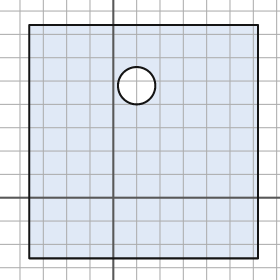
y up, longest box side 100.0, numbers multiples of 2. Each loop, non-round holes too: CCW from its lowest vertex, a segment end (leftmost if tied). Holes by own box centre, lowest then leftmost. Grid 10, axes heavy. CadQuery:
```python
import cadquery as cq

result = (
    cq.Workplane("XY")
    .moveTo(-36.0, -26.0)
    .lineTo(62.0, -26.0)
    .lineTo(62.0, 74.0)
    .lineTo(-36.0, 74.0)
    .close()
    .moveTo(10.0, 48.0)
    .circle(8.0)
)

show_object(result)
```